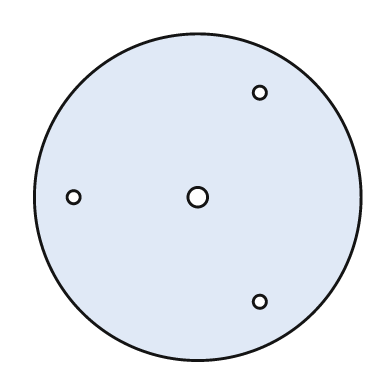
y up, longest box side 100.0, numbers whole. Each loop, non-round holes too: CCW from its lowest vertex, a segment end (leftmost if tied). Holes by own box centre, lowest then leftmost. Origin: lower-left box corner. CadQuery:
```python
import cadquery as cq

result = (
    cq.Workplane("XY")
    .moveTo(50.0, 50.0)
    .circle(50.0)
    .moveTo(69.0, 18.0)
    .circle(2.0)
    .moveTo(12.0, 50.0)
    .circle(2.0)
    .moveTo(50.0, 50.0)
    .circle(3.0)
    .moveTo(69.0, 82.0)
    .circle(2.0)
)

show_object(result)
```